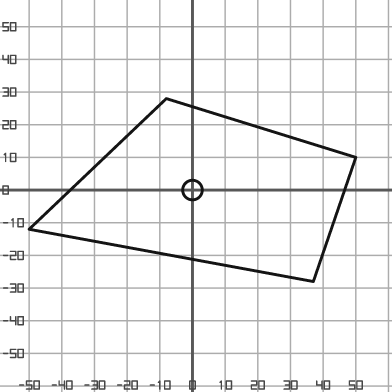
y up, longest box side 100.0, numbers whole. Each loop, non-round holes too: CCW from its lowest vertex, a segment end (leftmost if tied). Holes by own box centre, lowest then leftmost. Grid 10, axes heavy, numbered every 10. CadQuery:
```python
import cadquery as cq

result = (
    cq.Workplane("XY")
    .moveTo(37.0, -28.0)
    .lineTo(50.0, 10.0)
    .lineTo(-8.0, 28.0)
    .lineTo(-50.0, -12.0)
    .close()
    .moveTo(0.0, 0.0)
    .circle(3.0)
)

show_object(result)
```